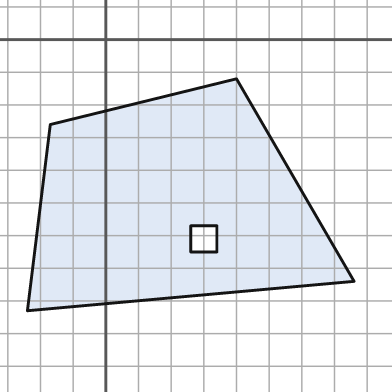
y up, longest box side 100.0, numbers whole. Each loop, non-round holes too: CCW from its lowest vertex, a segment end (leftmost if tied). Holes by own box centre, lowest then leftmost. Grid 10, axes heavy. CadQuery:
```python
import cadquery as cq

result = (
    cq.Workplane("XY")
    .moveTo(-24.0, -83.0)
    .lineTo(76.0, -74.0)
    .lineTo(40.0, -12.0)
    .lineTo(-17.0, -26.0)
    .close()
    .moveTo(26.0, -65.0)
    .lineTo(34.0, -65.0)
    .lineTo(34.0, -57.0)
    .lineTo(26.0, -57.0)
    .close()
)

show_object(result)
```